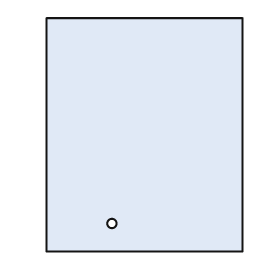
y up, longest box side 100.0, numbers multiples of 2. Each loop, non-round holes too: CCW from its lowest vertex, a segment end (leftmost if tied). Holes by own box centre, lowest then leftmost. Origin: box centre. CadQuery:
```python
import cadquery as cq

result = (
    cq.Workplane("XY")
    .moveTo(-42.0, -50.0)
    .lineTo(42.0, -50.0)
    .lineTo(42.0, 50.0)
    .lineTo(-42.0, 50.0)
    .close()
    .moveTo(-14.0, -38.0)
    .circle(2.0)
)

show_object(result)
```